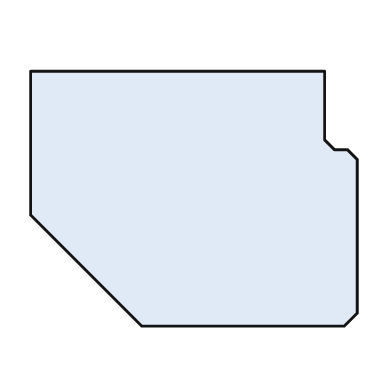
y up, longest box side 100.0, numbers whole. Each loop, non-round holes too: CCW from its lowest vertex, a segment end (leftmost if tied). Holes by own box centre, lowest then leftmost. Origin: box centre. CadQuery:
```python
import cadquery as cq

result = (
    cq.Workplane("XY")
    .moveTo(-16.0, -39.0)
    .lineTo(46.0, -39.0)
    .lineTo(50.0, -35.0)
    .lineTo(50.0, 12.0)
    .lineTo(47.0, 15.0)
    .lineTo(43.0, 15.0)
    .lineTo(40.0, 18.0)
    .lineTo(40.0, 39.0)
    .lineTo(-50.0, 39.0)
    .lineTo(-50.0, -5.0)
    .close()
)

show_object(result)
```